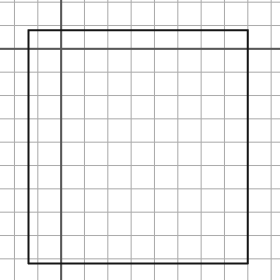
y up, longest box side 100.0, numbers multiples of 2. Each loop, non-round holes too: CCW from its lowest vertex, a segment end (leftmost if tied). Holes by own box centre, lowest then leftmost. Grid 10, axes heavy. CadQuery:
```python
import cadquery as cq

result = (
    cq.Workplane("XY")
    .moveTo(-14.0, -92.0)
    .lineTo(80.0, -92.0)
    .lineTo(80.0, 8.0)
    .lineTo(-14.0, 8.0)
    .close()
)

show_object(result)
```